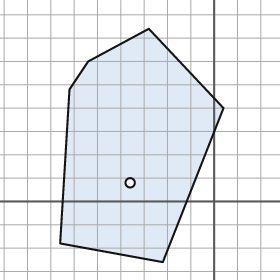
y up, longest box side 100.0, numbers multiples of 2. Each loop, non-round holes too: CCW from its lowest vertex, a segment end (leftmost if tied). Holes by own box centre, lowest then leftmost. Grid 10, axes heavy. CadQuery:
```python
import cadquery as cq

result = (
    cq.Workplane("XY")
    .moveTo(-22.0, -26.0)
    .lineTo(4.0, 40.0)
    .lineTo(-28.0, 74.0)
    .lineTo(-54.0, 60.0)
    .lineTo(-62.0, 48.0)
    .lineTo(-66.0, -18.0)
    .close()
    .moveTo(-36.0, 8.0)
    .circle(2.0)
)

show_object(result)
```